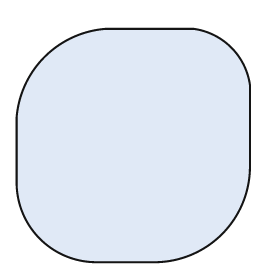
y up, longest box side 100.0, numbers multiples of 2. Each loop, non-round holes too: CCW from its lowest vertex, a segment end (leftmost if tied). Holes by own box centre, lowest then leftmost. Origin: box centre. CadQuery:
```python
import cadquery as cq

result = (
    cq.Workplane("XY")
    .moveTo(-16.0, -50.0)
    .lineTo(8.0, -50.0)
    .threePointArc((38.0, -38.0), (50.0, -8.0))
    .lineTo(50.0, 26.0)
    .threePointArc((42.0, 42.0), (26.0, 50.0))
    .lineTo(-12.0, 50.0)
    .threePointArc((-38.0, 38.0), (-50.0, 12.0))
    .lineTo(-50.0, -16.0)
    .threePointArc((-40.0, -40.0), (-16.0, -50.0))
    .close()
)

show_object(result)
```